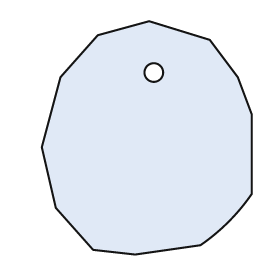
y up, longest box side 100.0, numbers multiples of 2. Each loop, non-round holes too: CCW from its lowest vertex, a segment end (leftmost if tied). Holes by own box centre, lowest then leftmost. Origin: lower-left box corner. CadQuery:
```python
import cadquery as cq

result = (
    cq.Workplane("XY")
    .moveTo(40.0, 0.0)
    .lineTo(68.0, 4.0)
    .threePointArc((80.0, 14.0), (90.0, 26.0))
    .lineTo(90.0, 60.0)
    .lineTo(84.0, 76.0)
    .lineTo(72.0, 92.0)
    .lineTo(46.0, 100.0)
    .lineTo(24.0, 94.0)
    .lineTo(8.0, 76.0)
    .lineTo(0.0, 46.0)
    .lineTo(6.0, 20.0)
    .lineTo(22.0, 2.0)
    .close()
    .moveTo(48.0, 78.0)
    .circle(4.0)
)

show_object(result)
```